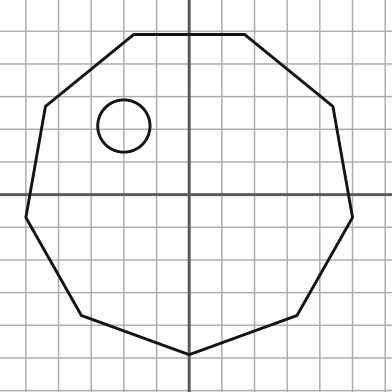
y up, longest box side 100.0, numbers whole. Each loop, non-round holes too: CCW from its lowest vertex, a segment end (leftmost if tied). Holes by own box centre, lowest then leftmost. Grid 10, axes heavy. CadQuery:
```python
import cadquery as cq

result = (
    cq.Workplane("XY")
    .moveTo(0.0, -49.0)
    .lineTo(33.0, -37.0)
    .lineTo(50.0, -7.0)
    .lineTo(44.0, 27.0)
    .lineTo(17.0, 49.0)
    .lineTo(-17.0, 49.0)
    .lineTo(-44.0, 27.0)
    .lineTo(-50.0, -7.0)
    .lineTo(-33.0, -37.0)
    .close()
    .moveTo(-20.0, 21.0)
    .circle(8.0)
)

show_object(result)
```